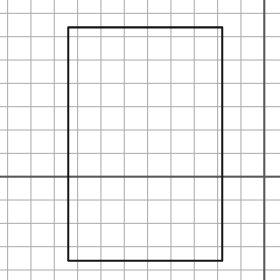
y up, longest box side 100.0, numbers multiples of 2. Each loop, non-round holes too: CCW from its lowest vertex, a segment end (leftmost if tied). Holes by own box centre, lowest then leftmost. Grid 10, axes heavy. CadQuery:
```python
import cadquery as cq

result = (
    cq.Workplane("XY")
    .moveTo(-84.0, -36.0)
    .lineTo(-18.0, -36.0)
    .lineTo(-18.0, 64.0)
    .lineTo(-84.0, 64.0)
    .close()
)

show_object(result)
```